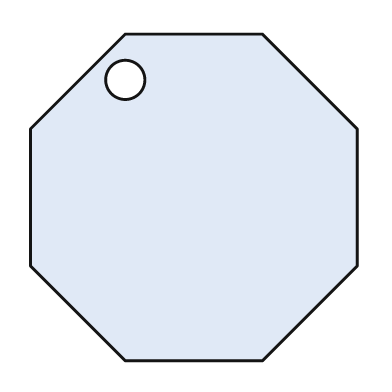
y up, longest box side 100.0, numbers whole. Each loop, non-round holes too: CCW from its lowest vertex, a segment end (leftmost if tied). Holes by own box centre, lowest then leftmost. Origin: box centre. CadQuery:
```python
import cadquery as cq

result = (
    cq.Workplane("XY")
    .moveTo(-21.0, -50.0)
    .lineTo(21.0, -50.0)
    .lineTo(50.0, -21.0)
    .lineTo(50.0, 21.0)
    .lineTo(21.0, 50.0)
    .lineTo(-21.0, 50.0)
    .lineTo(-50.0, 21.0)
    .lineTo(-50.0, -21.0)
    .close()
    .moveTo(-21.0, 36.0)
    .circle(6.0)
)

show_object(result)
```